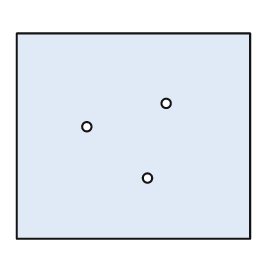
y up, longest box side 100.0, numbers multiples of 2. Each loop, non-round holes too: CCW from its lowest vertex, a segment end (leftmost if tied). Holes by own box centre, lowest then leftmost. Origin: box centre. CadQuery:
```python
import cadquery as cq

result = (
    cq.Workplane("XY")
    .moveTo(-50.0, -44.0)
    .lineTo(50.0, -44.0)
    .lineTo(50.0, 44.0)
    .lineTo(-50.0, 44.0)
    .close()
    .moveTo(6.0, -18.0)
    .circle(2.0)
    .moveTo(-20.0, 4.0)
    .circle(2.0)
    .moveTo(14.0, 14.0)
    .circle(2.0)
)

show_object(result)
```